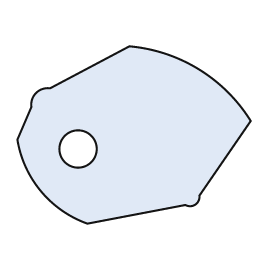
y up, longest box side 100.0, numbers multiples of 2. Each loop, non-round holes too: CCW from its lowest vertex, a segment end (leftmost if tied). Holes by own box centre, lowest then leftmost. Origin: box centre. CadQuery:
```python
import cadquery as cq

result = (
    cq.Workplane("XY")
    .moveTo(-20.0, -38.0)
    .lineTo(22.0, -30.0)
    .threePointArc((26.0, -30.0), (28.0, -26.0))
    .lineTo(50.0, 6.0)
    .threePointArc((28.0, 28.0), (-2.0, 38.0))
    .lineTo(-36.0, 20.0)
    .threePointArc((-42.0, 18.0), (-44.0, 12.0))
    .lineTo(-50.0, -2.0)
    .threePointArc((-40.0, -24.0), (-20.0, -38.0))
    .close()
    .moveTo(-24.0, -6.0)
    .circle(8.0)
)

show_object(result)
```